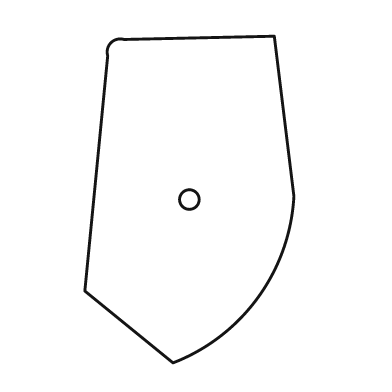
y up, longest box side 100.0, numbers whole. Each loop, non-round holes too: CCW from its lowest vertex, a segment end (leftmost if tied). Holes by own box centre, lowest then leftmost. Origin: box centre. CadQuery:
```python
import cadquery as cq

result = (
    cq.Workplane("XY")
    .moveTo(-5.0, -50.0)
    .threePointArc((21.0, -30.0), (32.0, 1.0))
    .lineTo(26.0, 50.0)
    .lineTo(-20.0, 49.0)
    .threePointArc((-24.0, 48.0), (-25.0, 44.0))
    .lineTo(-32.0, -28.0)
    .close()
    .moveTo(0.0, 0.0)
    .circle(3.0)
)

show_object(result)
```